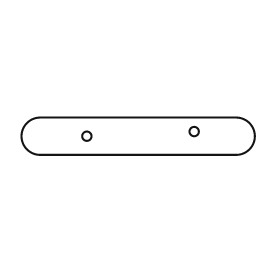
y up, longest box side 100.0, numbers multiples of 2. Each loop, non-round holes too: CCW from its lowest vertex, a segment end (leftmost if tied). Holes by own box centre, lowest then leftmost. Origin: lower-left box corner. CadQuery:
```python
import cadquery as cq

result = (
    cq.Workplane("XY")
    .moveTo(8.0, 0.0)
    .lineTo(92.0, 0.0)
    .threePointArc((100.0, 8.0), (92.0, 16.0))
    .lineTo(8.0, 16.0)
    .threePointArc((0.0, 8.0), (8.0, 0.0))
    .close()
    .moveTo(28.0, 8.0)
    .circle(2.0)
    .moveTo(74.0, 10.0)
    .circle(2.0)
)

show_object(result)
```